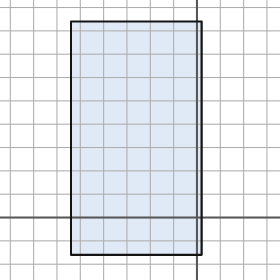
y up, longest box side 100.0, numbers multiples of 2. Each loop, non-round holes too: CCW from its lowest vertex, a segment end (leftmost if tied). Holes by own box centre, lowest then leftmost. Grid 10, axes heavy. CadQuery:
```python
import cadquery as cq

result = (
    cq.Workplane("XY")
    .moveTo(-54.0, -16.0)
    .lineTo(2.0, -16.0)
    .lineTo(2.0, 84.0)
    .lineTo(-54.0, 84.0)
    .close()
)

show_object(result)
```